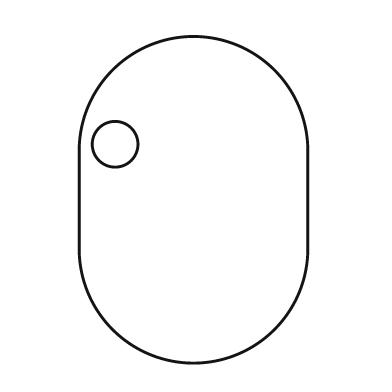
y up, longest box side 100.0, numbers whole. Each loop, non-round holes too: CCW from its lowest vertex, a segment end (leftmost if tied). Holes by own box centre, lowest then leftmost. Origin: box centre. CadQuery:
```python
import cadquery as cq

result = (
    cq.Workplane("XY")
    .moveTo(-35.0, -15.0)
    .threePointArc((0.0, -50.0), (35.0, -15.0))
    .lineTo(35.0, 15.0)
    .threePointArc((0.0, 50.0), (-35.0, 15.0))
    .close()
    .moveTo(-24.0, 17.0)
    .circle(7.0)
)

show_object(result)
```